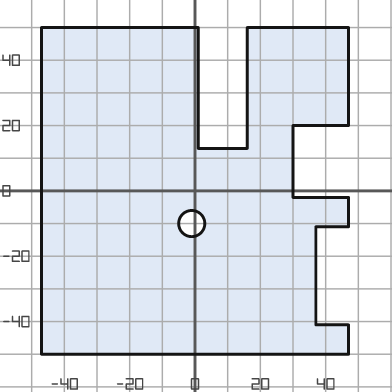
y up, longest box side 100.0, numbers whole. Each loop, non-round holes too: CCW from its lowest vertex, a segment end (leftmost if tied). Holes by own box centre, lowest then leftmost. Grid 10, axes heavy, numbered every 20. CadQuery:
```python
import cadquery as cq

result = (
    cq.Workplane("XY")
    .moveTo(-47.0, -50.0)
    .lineTo(47.0, -50.0)
    .lineTo(47.0, -41.0)
    .lineTo(37.0, -41.0)
    .lineTo(37.0, -11.0)
    .lineTo(47.0, -11.0)
    .lineTo(47.0, -2.0)
    .lineTo(30.0, -2.0)
    .lineTo(30.0, 20.0)
    .lineTo(47.0, 20.0)
    .lineTo(47.0, 50.0)
    .lineTo(16.0, 50.0)
    .lineTo(16.0, 13.0)
    .lineTo(1.0, 13.0)
    .lineTo(1.0, 50.0)
    .lineTo(-47.0, 50.0)
    .close()
    .moveTo(-1.0, -10.0)
    .circle(4.0)
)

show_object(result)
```